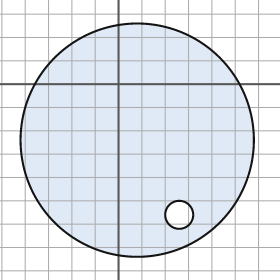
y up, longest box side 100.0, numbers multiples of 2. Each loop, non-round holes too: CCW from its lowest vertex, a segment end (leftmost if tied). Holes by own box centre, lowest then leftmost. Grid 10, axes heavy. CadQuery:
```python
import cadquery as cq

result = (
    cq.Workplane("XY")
    .moveTo(8.0, -24.0)
    .circle(50.0)
    .moveTo(26.0, -56.0)
    .circle(6.0)
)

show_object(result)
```